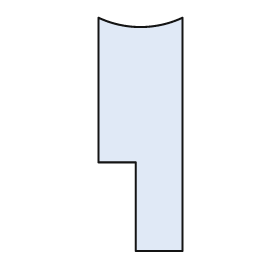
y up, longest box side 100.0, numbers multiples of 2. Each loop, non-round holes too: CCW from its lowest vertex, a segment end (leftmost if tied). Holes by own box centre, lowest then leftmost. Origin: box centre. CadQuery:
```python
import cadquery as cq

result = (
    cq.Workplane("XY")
    .moveTo(-2.0, -50.0)
    .lineTo(18.0, -50.0)
    .lineTo(18.0, 50.0)
    .threePointArc((0.0, 46.0), (-18.0, 50.0))
    .lineTo(-18.0, -12.0)
    .lineTo(-2.0, -12.0)
    .close()
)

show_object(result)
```